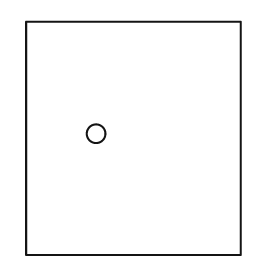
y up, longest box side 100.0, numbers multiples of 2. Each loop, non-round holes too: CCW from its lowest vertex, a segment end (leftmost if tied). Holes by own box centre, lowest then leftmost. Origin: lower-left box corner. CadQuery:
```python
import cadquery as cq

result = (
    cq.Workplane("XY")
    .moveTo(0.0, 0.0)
    .lineTo(92.0, 0.0)
    .lineTo(92.0, 100.0)
    .lineTo(0.0, 100.0)
    .close()
    .moveTo(30.0, 52.0)
    .circle(4.0)
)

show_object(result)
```